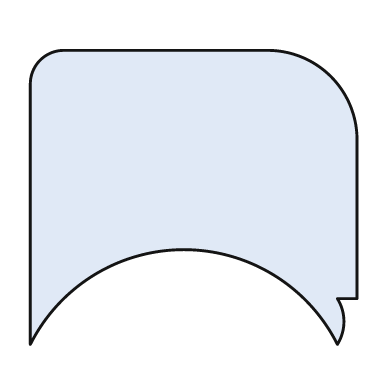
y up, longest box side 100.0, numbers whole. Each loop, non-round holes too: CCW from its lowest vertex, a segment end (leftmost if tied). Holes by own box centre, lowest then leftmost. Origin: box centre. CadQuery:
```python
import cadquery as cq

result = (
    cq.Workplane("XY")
    .moveTo(-50.0, -45.0)
    .threePointArc((-3.0, -16.0), (44.0, -45.0))
    .threePointArc((46.0, -38.0), (44.0, -31.0))
    .lineTo(50.0, -31.0)
    .lineTo(50.0, 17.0)
    .threePointArc((42.0, 37.0), (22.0, 45.0))
    .lineTo(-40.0, 45.0)
    .threePointArc((-47.0, 42.0), (-50.0, 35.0))
    .close()
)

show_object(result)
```